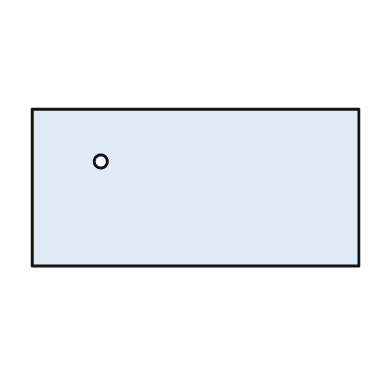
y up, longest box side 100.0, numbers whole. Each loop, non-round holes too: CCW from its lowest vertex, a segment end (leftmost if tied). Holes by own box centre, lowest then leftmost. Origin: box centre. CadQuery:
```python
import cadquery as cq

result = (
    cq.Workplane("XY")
    .moveTo(-50.0, -24.0)
    .lineTo(50.0, -24.0)
    .lineTo(50.0, 24.0)
    .lineTo(-50.0, 24.0)
    .close()
    .moveTo(-29.0, 8.0)
    .circle(2.0)
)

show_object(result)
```